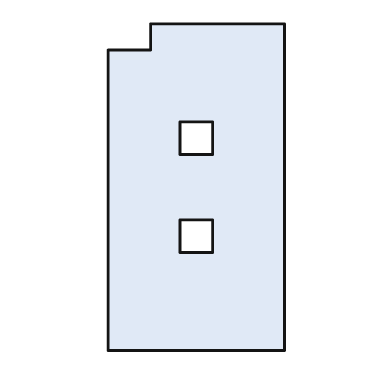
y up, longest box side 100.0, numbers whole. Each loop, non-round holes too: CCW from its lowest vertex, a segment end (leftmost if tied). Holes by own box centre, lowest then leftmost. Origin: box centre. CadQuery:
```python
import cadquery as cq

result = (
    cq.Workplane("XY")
    .moveTo(-27.0, -50.0)
    .lineTo(27.0, -50.0)
    .lineTo(27.0, 50.0)
    .lineTo(-14.0, 50.0)
    .lineTo(-14.0, 42.0)
    .lineTo(-27.0, 42.0)
    .close()
    .moveTo(-5.0, -20.0)
    .lineTo(5.0, -20.0)
    .lineTo(5.0, -10.0)
    .lineTo(-5.0, -10.0)
    .close()
    .moveTo(-5.0, 10.0)
    .lineTo(5.0, 10.0)
    .lineTo(5.0, 20.0)
    .lineTo(-5.0, 20.0)
    .close()
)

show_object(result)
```